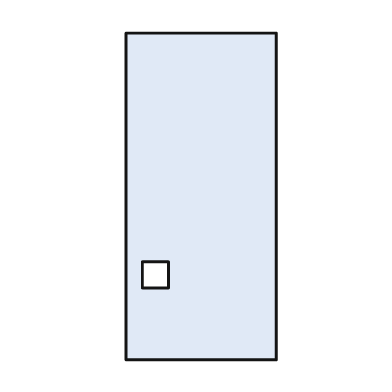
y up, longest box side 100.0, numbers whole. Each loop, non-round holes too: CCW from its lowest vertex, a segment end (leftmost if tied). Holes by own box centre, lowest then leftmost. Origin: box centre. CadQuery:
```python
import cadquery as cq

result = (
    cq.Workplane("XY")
    .moveTo(-23.0, -50.0)
    .lineTo(23.0, -50.0)
    .lineTo(23.0, 50.0)
    .lineTo(-23.0, 50.0)
    .close()
    .moveTo(-18.0, -28.0)
    .lineTo(-10.0, -28.0)
    .lineTo(-10.0, -20.0)
    .lineTo(-18.0, -20.0)
    .close()
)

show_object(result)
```